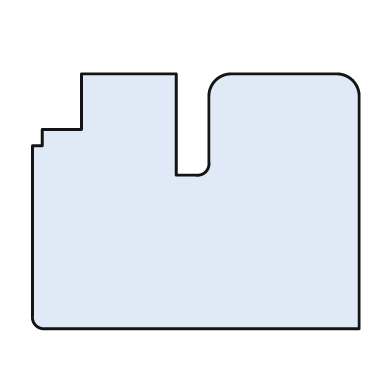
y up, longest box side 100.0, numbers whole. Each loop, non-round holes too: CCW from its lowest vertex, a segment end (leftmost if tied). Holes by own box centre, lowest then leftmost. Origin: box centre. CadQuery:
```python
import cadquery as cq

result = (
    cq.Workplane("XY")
    .moveTo(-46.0, -39.0)
    .lineTo(50.0, -39.0)
    .lineTo(50.0, 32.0)
    .threePointArc((48.0, 37.0), (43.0, 39.0))
    .lineTo(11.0, 39.0)
    .threePointArc((6.0, 37.0), (4.0, 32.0))
    .lineTo(4.0, 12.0)
    .threePointArc((3.0, 9.0), (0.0, 8.0))
    .lineTo(-6.0, 8.0)
    .lineTo(-6.0, 39.0)
    .lineTo(-35.0, 39.0)
    .lineTo(-35.0, 22.0)
    .lineTo(-47.0, 22.0)
    .lineTo(-47.0, 17.0)
    .lineTo(-50.0, 17.0)
    .lineTo(-50.0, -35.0)
    .threePointArc((-49.0, -38.0), (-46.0, -39.0))
    .close()
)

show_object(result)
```